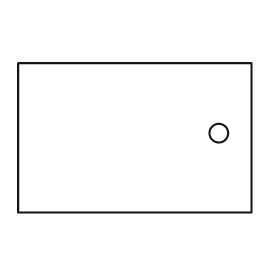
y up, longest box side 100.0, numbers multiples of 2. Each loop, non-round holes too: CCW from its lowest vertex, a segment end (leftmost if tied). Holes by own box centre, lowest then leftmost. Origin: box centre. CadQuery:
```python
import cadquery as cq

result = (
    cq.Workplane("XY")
    .moveTo(-50.0, -32.0)
    .lineTo(50.0, -32.0)
    .lineTo(50.0, 32.0)
    .lineTo(-50.0, 32.0)
    .close()
    .moveTo(36.0, 2.0)
    .circle(4.0)
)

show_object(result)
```